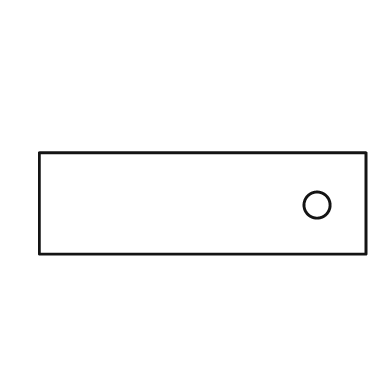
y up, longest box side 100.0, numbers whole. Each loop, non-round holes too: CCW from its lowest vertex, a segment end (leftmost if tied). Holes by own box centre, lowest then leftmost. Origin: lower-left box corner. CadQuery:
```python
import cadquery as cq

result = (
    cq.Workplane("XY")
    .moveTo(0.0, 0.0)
    .lineTo(100.0, 0.0)
    .lineTo(100.0, 31.0)
    .lineTo(0.0, 31.0)
    .close()
    .moveTo(85.0, 15.0)
    .circle(4.0)
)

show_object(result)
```